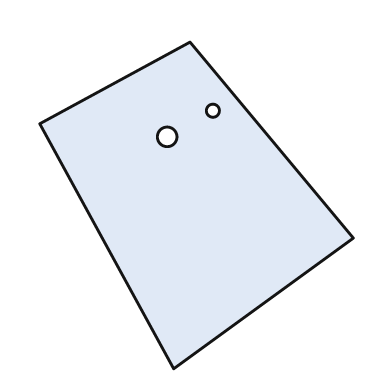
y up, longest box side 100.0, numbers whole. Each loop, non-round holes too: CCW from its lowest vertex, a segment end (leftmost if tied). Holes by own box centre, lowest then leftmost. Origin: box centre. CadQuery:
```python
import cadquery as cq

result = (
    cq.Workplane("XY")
    .moveTo(-7.0, -50.0)
    .lineTo(48.0, -10.0)
    .lineTo(-2.0, 50.0)
    .lineTo(-48.0, 25.0)
    .close()
    .moveTo(-9.0, 21.0)
    .circle(3.0)
    .moveTo(5.0, 29.0)
    .circle(2.0)
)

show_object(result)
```